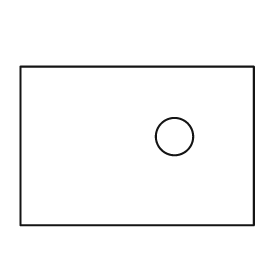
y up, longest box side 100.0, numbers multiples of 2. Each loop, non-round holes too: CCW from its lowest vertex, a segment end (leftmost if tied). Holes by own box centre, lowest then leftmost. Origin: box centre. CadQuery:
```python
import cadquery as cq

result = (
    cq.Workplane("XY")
    .moveTo(-50.0, -34.0)
    .lineTo(50.0, -34.0)
    .lineTo(50.0, 34.0)
    .lineTo(-50.0, 34.0)
    .close()
    .moveTo(16.0, 4.0)
    .circle(8.0)
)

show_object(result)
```